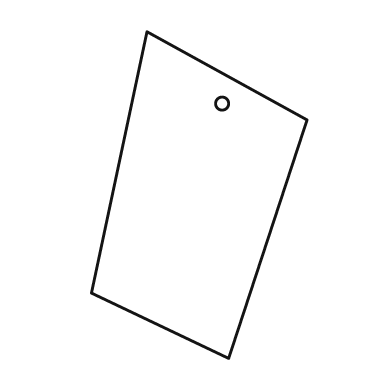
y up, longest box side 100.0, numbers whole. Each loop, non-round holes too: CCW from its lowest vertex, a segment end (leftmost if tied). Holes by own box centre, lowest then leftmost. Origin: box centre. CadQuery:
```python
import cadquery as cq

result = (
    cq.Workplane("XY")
    .moveTo(9.0, -50.0)
    .lineTo(33.0, 23.0)
    .lineTo(-16.0, 50.0)
    .lineTo(-33.0, -30.0)
    .close()
    .moveTo(7.0, 28.0)
    .circle(2.0)
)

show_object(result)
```